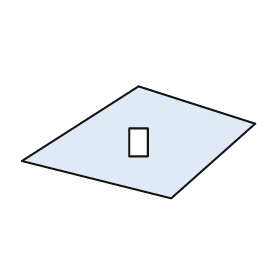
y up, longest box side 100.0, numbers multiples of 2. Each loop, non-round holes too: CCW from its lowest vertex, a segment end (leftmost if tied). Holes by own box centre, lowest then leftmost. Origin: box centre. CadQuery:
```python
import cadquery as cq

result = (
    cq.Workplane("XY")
    .moveTo(14.0, -24.0)
    .lineTo(50.0, 8.0)
    .lineTo(0.0, 24.0)
    .lineTo(-50.0, -8.0)
    .close()
    .moveTo(-4.0, -6.0)
    .lineTo(4.0, -6.0)
    .lineTo(4.0, 6.0)
    .lineTo(-4.0, 6.0)
    .close()
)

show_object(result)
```